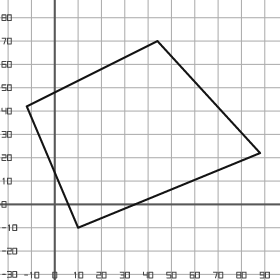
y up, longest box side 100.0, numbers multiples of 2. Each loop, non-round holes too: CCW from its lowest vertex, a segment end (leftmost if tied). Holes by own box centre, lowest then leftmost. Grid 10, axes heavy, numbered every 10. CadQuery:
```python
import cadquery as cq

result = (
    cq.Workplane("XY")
    .moveTo(10.0, -10.0)
    .lineTo(88.0, 22.0)
    .lineTo(44.0, 70.0)
    .lineTo(-12.0, 42.0)
    .close()
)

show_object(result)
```